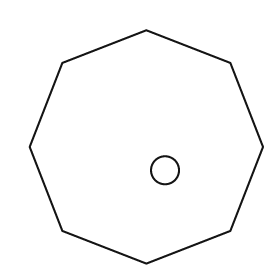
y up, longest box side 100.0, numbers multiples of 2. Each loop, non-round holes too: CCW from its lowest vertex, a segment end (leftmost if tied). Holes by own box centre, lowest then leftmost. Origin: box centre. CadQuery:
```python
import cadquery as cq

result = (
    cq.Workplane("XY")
    .moveTo(0.0, -50.0)
    .lineTo(36.0, -36.0)
    .lineTo(50.0, 0.0)
    .lineTo(36.0, 36.0)
    .lineTo(0.0, 50.0)
    .lineTo(-36.0, 36.0)
    .lineTo(-50.0, 0.0)
    .lineTo(-36.0, -36.0)
    .close()
    .moveTo(8.0, -10.0)
    .circle(6.0)
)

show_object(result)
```